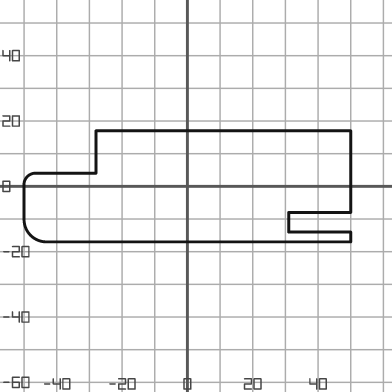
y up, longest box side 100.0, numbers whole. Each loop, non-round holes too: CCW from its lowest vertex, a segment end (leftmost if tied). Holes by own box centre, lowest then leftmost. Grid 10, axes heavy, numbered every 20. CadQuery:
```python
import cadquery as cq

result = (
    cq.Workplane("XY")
    .moveTo(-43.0, -17.0)
    .lineTo(50.0, -17.0)
    .lineTo(50.0, -14.0)
    .lineTo(31.0, -14.0)
    .lineTo(31.0, -8.0)
    .lineTo(50.0, -8.0)
    .lineTo(50.0, 17.0)
    .lineTo(-28.0, 17.0)
    .lineTo(-28.0, 4.0)
    .lineTo(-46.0, 4.0)
    .threePointArc((-49.0, 3.0), (-50.0, 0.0))
    .lineTo(-50.0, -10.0)
    .threePointArc((-48.0, -15.0), (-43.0, -17.0))
    .close()
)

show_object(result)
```